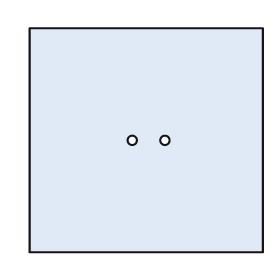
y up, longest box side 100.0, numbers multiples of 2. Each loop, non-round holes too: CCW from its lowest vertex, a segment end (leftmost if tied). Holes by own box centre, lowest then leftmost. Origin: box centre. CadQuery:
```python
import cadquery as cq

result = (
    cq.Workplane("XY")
    .moveTo(-50.0, -48.0)
    .lineTo(50.0, -48.0)
    .lineTo(50.0, 48.0)
    .lineTo(-50.0, 48.0)
    .close()
    .moveTo(-6.0, 0.0)
    .circle(2.0)
    .moveTo(8.0, 0.0)
    .circle(2.0)
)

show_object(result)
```